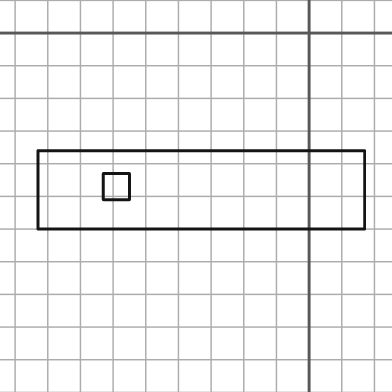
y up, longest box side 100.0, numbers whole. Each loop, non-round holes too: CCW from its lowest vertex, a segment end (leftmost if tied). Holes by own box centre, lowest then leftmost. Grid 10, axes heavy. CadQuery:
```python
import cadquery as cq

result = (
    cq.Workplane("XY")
    .moveTo(-83.0, -60.0)
    .lineTo(17.0, -60.0)
    .lineTo(17.0, -36.0)
    .lineTo(-83.0, -36.0)
    .close()
    .moveTo(-63.0, -51.0)
    .lineTo(-55.0, -51.0)
    .lineTo(-55.0, -43.0)
    .lineTo(-63.0, -43.0)
    .close()
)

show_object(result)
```